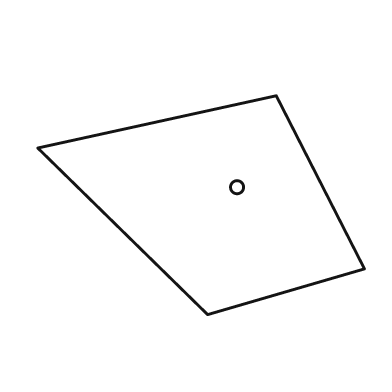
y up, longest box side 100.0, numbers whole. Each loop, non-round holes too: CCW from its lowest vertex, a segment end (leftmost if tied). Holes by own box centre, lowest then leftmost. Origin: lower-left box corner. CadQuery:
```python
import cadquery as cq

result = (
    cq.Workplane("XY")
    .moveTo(52.0, 0.0)
    .lineTo(100.0, 14.0)
    .lineTo(73.0, 67.0)
    .lineTo(0.0, 51.0)
    .close()
    .moveTo(61.0, 39.0)
    .circle(2.0)
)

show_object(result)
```